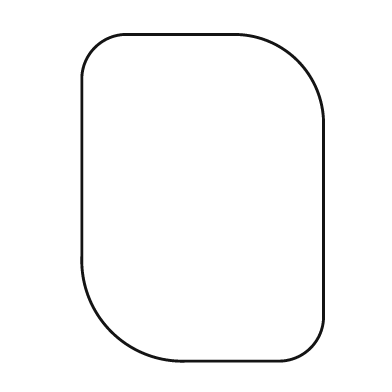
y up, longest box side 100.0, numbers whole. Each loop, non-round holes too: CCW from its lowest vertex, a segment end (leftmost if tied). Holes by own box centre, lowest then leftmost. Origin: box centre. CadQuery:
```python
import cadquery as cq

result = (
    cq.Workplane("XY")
    .moveTo(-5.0, -50.0)
    .lineTo(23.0, -50.0)
    .threePointArc((33.0, -46.0), (37.0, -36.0))
    .lineTo(37.0, 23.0)
    .threePointArc((29.0, 42.0), (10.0, 50.0))
    .lineTo(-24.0, 50.0)
    .threePointArc((-33.0, 46.0), (-37.0, 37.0))
    .lineTo(-37.0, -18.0)
    .threePointArc((-28.0, -41.0), (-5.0, -50.0))
    .close()
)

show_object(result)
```